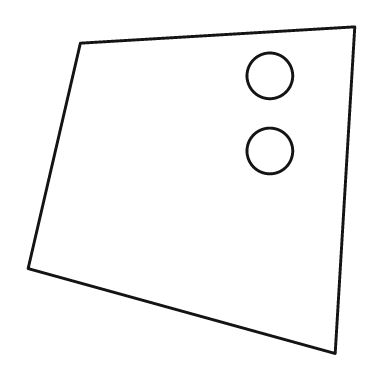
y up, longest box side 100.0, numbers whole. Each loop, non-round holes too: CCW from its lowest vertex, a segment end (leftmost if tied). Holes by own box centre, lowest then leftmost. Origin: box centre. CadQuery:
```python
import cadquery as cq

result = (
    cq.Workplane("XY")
    .moveTo(44.0, -50.0)
    .lineTo(50.0, 50.0)
    .lineTo(-34.0, 45.0)
    .lineTo(-50.0, -24.0)
    .close()
    .moveTo(24.0, 12.0)
    .circle(7.0)
    .moveTo(24.0, 35.0)
    .circle(7.0)
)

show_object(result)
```